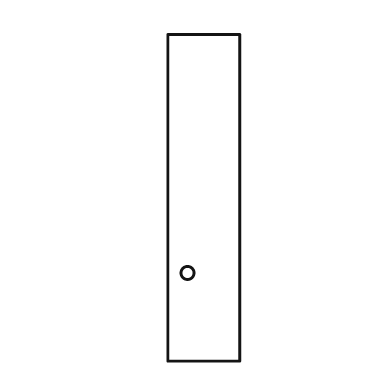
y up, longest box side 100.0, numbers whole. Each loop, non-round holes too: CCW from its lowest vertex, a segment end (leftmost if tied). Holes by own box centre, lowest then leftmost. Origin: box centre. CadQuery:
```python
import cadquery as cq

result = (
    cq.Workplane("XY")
    .moveTo(-11.0, -50.0)
    .lineTo(11.0, -50.0)
    .lineTo(11.0, 50.0)
    .lineTo(-11.0, 50.0)
    .close()
    .moveTo(-5.0, -23.0)
    .circle(2.0)
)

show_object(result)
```